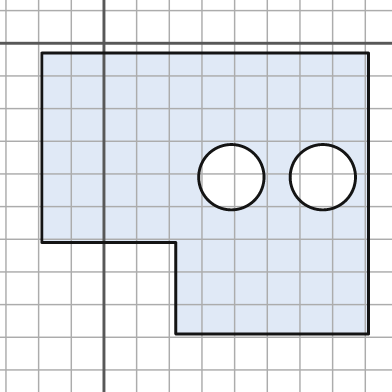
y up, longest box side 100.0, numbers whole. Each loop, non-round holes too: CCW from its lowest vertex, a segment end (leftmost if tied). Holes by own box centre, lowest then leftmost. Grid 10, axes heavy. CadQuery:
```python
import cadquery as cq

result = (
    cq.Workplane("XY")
    .moveTo(22.0, -89.0)
    .lineTo(81.0, -89.0)
    .lineTo(81.0, -3.0)
    .lineTo(-19.0, -3.0)
    .lineTo(-19.0, -61.0)
    .lineTo(22.0, -61.0)
    .close()
    .moveTo(39.0, -41.0)
    .circle(10.0)
    .moveTo(67.0, -41.0)
    .circle(10.0)
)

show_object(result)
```